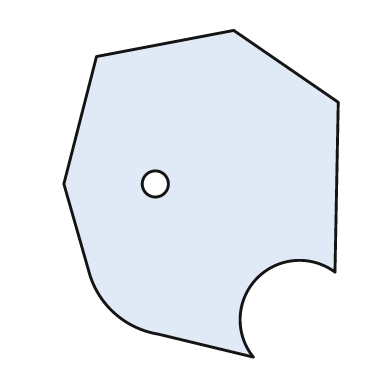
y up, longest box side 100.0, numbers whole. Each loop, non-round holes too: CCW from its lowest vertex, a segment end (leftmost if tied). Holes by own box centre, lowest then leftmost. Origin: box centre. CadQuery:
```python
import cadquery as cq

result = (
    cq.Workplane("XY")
    .moveTo(16.0, -50.0)
    .threePointArc((17.0, -26.0), (41.0, -24.0))
    .lineTo(42.0, 28.0)
    .lineTo(10.0, 50.0)
    .lineTo(-32.0, 42.0)
    .lineTo(-42.0, 3.0)
    .lineTo(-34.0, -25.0)
    .threePointArc((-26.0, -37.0), (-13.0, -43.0))
    .close()
    .moveTo(-14.0, 3.0)
    .circle(4.0)
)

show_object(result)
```